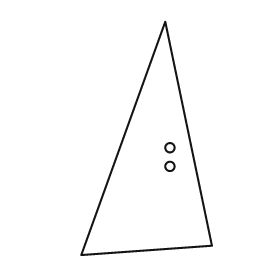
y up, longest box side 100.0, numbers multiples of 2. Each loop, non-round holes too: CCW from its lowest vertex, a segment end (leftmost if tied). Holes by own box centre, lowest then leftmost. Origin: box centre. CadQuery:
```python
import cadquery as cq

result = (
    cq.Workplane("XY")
    .moveTo(-28.0, -50.0)
    .lineTo(28.0, -46.0)
    .lineTo(8.0, 50.0)
    .close()
    .moveTo(10.0, -12.0)
    .circle(2.0)
    .moveTo(10.0, -4.0)
    .circle(2.0)
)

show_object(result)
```